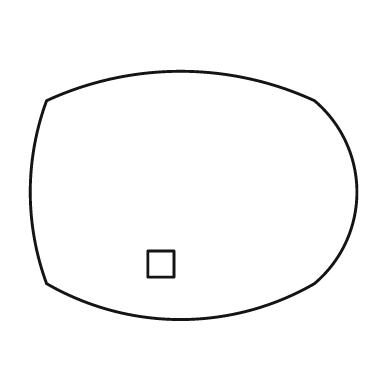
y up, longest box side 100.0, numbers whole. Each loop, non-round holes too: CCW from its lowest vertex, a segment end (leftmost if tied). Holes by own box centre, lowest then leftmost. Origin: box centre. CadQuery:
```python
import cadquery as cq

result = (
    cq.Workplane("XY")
    .moveTo(-45.0, -27.0)
    .threePointArc((-4.0, -38.0), (37.0, -27.0))
    .threePointArc((50.0, 1.0), (37.0, 29.0))
    .threePointArc((-4.0, 38.0), (-45.0, 29.0))
    .threePointArc((-50.0, 1.0), (-45.0, -27.0))
    .close()
    .moveTo(-14.0, -25.0)
    .lineTo(-6.0, -25.0)
    .lineTo(-6.0, -17.0)
    .lineTo(-14.0, -17.0)
    .close()
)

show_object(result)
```